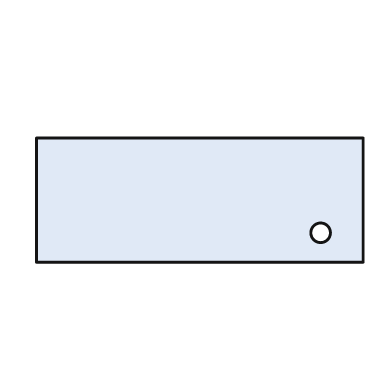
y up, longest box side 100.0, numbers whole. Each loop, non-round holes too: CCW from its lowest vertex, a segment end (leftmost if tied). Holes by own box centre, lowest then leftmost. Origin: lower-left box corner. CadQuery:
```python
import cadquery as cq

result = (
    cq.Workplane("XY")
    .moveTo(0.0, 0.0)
    .lineTo(100.0, 0.0)
    .lineTo(100.0, 38.0)
    .lineTo(0.0, 38.0)
    .close()
    .moveTo(87.0, 9.0)
    .circle(3.0)
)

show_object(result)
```